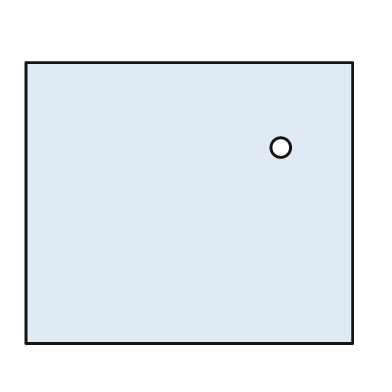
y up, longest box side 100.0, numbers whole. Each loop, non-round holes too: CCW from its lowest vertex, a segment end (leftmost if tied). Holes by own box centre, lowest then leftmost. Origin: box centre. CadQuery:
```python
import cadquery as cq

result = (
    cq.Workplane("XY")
    .moveTo(-50.0, -43.0)
    .lineTo(50.0, -43.0)
    .lineTo(50.0, 43.0)
    .lineTo(-50.0, 43.0)
    .close()
    .moveTo(28.0, 17.0)
    .circle(3.0)
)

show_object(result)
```